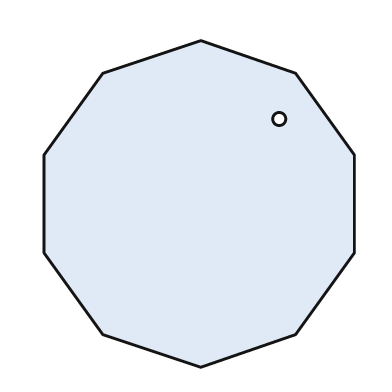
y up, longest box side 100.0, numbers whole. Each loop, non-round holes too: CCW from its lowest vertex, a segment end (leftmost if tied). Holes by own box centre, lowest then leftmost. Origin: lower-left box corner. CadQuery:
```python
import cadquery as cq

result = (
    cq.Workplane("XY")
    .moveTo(48.0, 0.0)
    .lineTo(77.0, 10.0)
    .lineTo(95.0, 35.0)
    .lineTo(95.0, 65.0)
    .lineTo(77.0, 90.0)
    .lineTo(48.0, 100.0)
    .lineTo(18.0, 90.0)
    .lineTo(0.0, 65.0)
    .lineTo(0.0, 35.0)
    .lineTo(18.0, 10.0)
    .close()
    .moveTo(72.0, 76.0)
    .circle(2.0)
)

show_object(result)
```